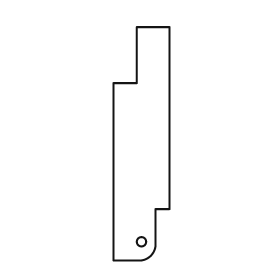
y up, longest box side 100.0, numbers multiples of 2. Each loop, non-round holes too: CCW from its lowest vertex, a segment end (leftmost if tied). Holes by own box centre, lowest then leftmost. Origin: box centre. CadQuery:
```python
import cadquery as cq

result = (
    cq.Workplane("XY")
    .moveTo(-12.0, -50.0)
    .lineTo(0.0, -50.0)
    .threePointArc((4.0, -48.0), (6.0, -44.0))
    .lineTo(6.0, -28.0)
    .lineTo(12.0, -28.0)
    .lineTo(12.0, 50.0)
    .lineTo(-2.0, 50.0)
    .lineTo(-2.0, 26.0)
    .lineTo(-12.0, 26.0)
    .close()
    .moveTo(0.0, -42.0)
    .circle(2.0)
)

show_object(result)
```